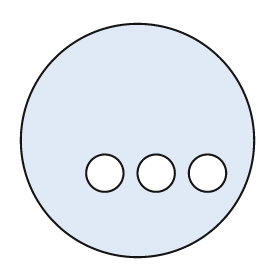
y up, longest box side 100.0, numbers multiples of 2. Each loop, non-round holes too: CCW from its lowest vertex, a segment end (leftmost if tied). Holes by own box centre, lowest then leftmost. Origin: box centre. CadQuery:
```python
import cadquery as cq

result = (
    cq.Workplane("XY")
    .moveTo(0.0, 0.0)
    .circle(50.0)
    .moveTo(-14.0, -14.0)
    .circle(8.0)
    .moveTo(8.0, -14.0)
    .circle(8.0)
    .moveTo(30.0, -14.0)
    .circle(8.0)
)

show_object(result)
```